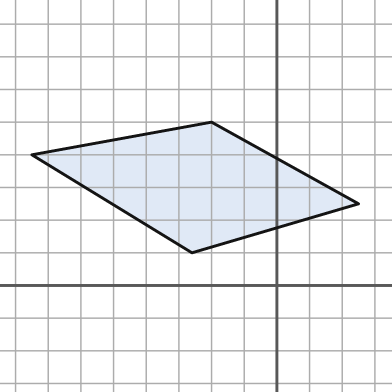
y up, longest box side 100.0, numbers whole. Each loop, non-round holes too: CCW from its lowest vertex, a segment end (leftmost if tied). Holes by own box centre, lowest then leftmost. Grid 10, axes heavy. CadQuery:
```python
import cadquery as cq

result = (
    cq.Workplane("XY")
    .moveTo(-26.0, 10.0)
    .lineTo(25.0, 25.0)
    .lineTo(-20.0, 50.0)
    .lineTo(-75.0, 40.0)
    .close()
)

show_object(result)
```